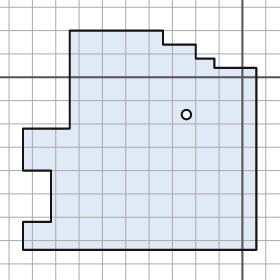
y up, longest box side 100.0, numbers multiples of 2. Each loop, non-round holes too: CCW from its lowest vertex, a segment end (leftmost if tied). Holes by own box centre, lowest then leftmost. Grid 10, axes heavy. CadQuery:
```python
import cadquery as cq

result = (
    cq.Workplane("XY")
    .moveTo(-94.0, -74.0)
    .lineTo(6.0, -74.0)
    .lineTo(6.0, 4.0)
    .lineTo(-12.0, 4.0)
    .lineTo(-12.0, 8.0)
    .lineTo(-20.0, 8.0)
    .lineTo(-20.0, 14.0)
    .lineTo(-34.0, 14.0)
    .lineTo(-34.0, 20.0)
    .lineTo(-74.0, 20.0)
    .lineTo(-74.0, -22.0)
    .lineTo(-94.0, -22.0)
    .lineTo(-94.0, -40.0)
    .lineTo(-82.0, -40.0)
    .lineTo(-82.0, -62.0)
    .lineTo(-94.0, -62.0)
    .close()
    .moveTo(-24.0, -16.0)
    .circle(2.0)
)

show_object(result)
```